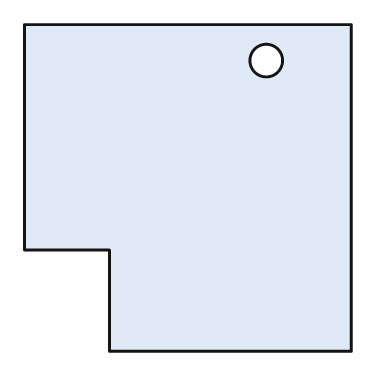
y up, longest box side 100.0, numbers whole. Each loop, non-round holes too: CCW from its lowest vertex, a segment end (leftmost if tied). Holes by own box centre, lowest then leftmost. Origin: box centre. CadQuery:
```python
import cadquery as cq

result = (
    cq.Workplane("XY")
    .moveTo(-24.0, -50.0)
    .lineTo(50.0, -50.0)
    .lineTo(50.0, 50.0)
    .lineTo(-50.0, 50.0)
    .lineTo(-50.0, -19.0)
    .lineTo(-24.0, -19.0)
    .close()
    .moveTo(24.0, 39.0)
    .circle(5.0)
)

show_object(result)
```